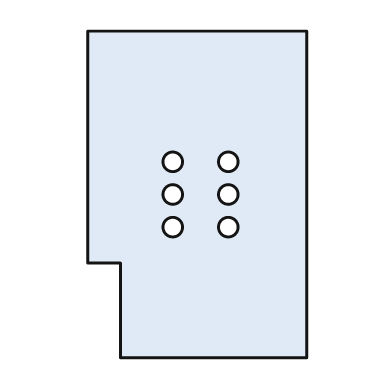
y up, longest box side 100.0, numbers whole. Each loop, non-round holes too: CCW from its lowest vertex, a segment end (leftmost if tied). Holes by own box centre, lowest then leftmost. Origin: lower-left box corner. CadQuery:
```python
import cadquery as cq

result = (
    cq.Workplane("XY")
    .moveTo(10.0, 0.0)
    .lineTo(67.0, 0.0)
    .lineTo(67.0, 100.0)
    .lineTo(0.0, 100.0)
    .lineTo(0.0, 29.0)
    .lineTo(10.0, 29.0)
    .close()
    .moveTo(26.0, 40.0)
    .circle(3.0)
    .moveTo(43.0, 40.0)
    .circle(3.0)
    .moveTo(26.0, 50.0)
    .circle(3.0)
    .moveTo(43.0, 50.0)
    .circle(3.0)
    .moveTo(26.0, 60.0)
    .circle(3.0)
    .moveTo(43.0, 60.0)
    .circle(3.0)
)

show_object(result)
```